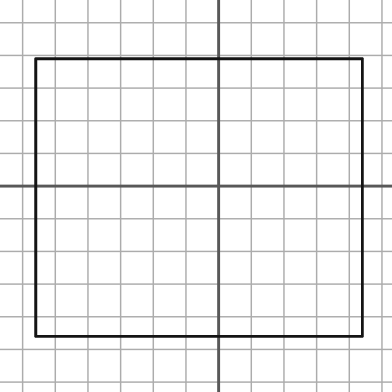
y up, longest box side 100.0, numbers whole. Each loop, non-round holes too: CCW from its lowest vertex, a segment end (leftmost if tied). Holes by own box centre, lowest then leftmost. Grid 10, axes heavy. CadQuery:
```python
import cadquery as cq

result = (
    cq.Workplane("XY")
    .moveTo(-56.0, -46.0)
    .lineTo(44.0, -46.0)
    .lineTo(44.0, 39.0)
    .lineTo(-56.0, 39.0)
    .close()
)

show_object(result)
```